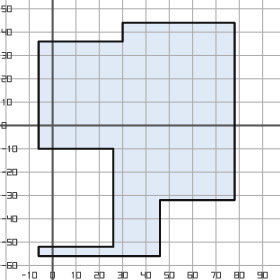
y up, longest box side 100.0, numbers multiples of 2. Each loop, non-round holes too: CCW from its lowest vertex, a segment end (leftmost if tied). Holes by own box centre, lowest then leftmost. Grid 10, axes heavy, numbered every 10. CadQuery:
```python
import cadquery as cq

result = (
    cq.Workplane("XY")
    .moveTo(-6.0, -56.0)
    .lineTo(46.0, -56.0)
    .lineTo(46.0, -32.0)
    .lineTo(78.0, -32.0)
    .lineTo(78.0, 44.0)
    .lineTo(30.0, 44.0)
    .lineTo(30.0, 36.0)
    .lineTo(-6.0, 36.0)
    .lineTo(-6.0, -10.0)
    .lineTo(26.0, -10.0)
    .lineTo(26.0, -52.0)
    .lineTo(-6.0, -52.0)
    .close()
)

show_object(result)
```